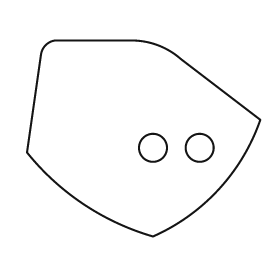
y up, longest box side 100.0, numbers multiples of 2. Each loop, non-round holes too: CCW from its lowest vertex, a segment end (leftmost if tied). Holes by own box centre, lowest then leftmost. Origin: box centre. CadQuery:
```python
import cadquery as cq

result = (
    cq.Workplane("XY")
    .moveTo(4.0, -42.0)
    .threePointArc((32.0, -22.0), (50.0, 8.0))
    .lineTo(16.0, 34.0)
    .threePointArc((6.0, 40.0), (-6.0, 42.0))
    .lineTo(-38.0, 42.0)
    .threePointArc((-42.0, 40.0), (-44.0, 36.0))
    .lineTo(-50.0, -6.0)
    .threePointArc((-26.0, -28.0), (4.0, -42.0))
    .close()
    .moveTo(4.0, -4.0)
    .circle(6.0)
    .moveTo(24.0, -4.0)
    .circle(6.0)
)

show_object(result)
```